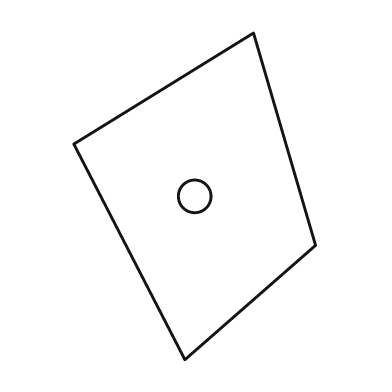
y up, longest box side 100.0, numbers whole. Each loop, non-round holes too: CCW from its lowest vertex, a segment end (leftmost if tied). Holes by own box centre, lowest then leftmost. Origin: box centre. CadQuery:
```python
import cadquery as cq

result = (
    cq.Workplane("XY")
    .moveTo(-3.0, -50.0)
    .lineTo(37.0, -15.0)
    .lineTo(18.0, 50.0)
    .lineTo(-37.0, 16.0)
    .close()
    .moveTo(0.0, 0.0)
    .circle(5.0)
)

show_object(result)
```